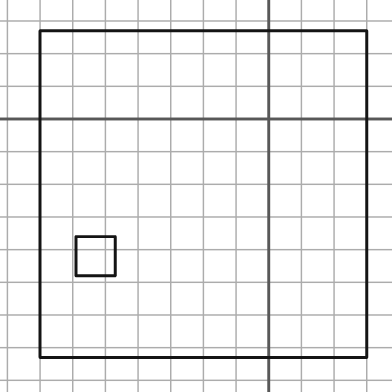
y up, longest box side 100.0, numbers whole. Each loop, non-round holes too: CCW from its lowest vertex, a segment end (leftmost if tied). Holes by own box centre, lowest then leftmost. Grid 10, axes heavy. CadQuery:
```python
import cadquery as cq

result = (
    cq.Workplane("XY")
    .moveTo(-70.0, -73.0)
    .lineTo(30.0, -73.0)
    .lineTo(30.0, 27.0)
    .lineTo(-70.0, 27.0)
    .close()
    .moveTo(-59.0, -48.0)
    .lineTo(-47.0, -48.0)
    .lineTo(-47.0, -36.0)
    .lineTo(-59.0, -36.0)
    .close()
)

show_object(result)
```